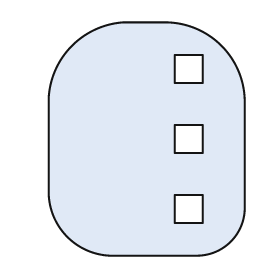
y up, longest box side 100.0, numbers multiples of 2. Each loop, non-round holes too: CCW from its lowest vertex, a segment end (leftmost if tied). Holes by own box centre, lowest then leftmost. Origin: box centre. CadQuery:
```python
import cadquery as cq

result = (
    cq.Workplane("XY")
    .moveTo(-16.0, -50.0)
    .lineTo(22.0, -50.0)
    .threePointArc((36.0, -44.0), (42.0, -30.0))
    .lineTo(42.0, 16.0)
    .threePointArc((32.0, 40.0), (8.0, 50.0))
    .lineTo(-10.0, 50.0)
    .threePointArc((-32.0, 40.0), (-42.0, 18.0))
    .lineTo(-42.0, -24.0)
    .threePointArc((-34.0, -42.0), (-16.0, -50.0))
    .close()
    .moveTo(12.0, -36.0)
    .lineTo(24.0, -36.0)
    .lineTo(24.0, -24.0)
    .lineTo(12.0, -24.0)
    .close()
    .moveTo(12.0, -6.0)
    .lineTo(24.0, -6.0)
    .lineTo(24.0, 6.0)
    .lineTo(12.0, 6.0)
    .close()
    .moveTo(12.0, 24.0)
    .lineTo(24.0, 24.0)
    .lineTo(24.0, 36.0)
    .lineTo(12.0, 36.0)
    .close()
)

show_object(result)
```